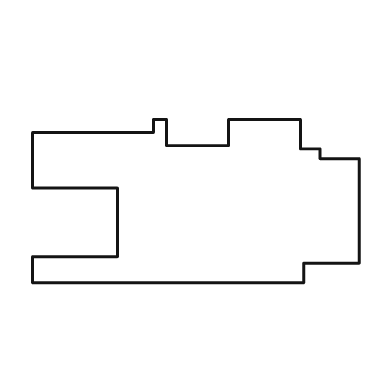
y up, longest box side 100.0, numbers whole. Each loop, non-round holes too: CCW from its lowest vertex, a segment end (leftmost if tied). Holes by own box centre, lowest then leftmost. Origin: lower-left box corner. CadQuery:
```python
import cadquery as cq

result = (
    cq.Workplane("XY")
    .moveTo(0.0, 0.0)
    .lineTo(83.0, 0.0)
    .lineTo(83.0, 6.0)
    .lineTo(100.0, 6.0)
    .lineTo(100.0, 38.0)
    .lineTo(88.0, 38.0)
    .lineTo(88.0, 41.0)
    .lineTo(82.0, 41.0)
    .lineTo(82.0, 50.0)
    .lineTo(60.0, 50.0)
    .lineTo(60.0, 42.0)
    .lineTo(41.0, 42.0)
    .lineTo(41.0, 50.0)
    .lineTo(37.0, 50.0)
    .lineTo(37.0, 46.0)
    .lineTo(0.0, 46.0)
    .lineTo(0.0, 29.0)
    .lineTo(26.0, 29.0)
    .lineTo(26.0, 8.0)
    .lineTo(0.0, 8.0)
    .close()
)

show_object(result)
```